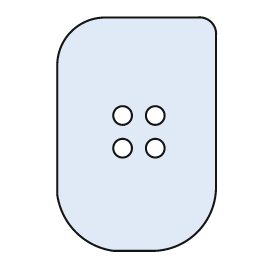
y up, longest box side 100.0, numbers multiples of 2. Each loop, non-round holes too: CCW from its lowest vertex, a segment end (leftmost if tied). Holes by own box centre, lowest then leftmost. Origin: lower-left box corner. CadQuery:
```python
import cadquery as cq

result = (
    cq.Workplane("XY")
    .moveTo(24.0, 0.0)
    .lineTo(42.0, 0.0)
    .threePointArc((60.0, 8.0), (68.0, 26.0))
    .lineTo(68.0, 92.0)
    .threePointArc((66.0, 98.0), (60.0, 100.0))
    .lineTo(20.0, 100.0)
    .threePointArc((6.0, 94.0), (0.0, 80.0))
    .lineTo(0.0, 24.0)
    .threePointArc((8.0, 8.0), (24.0, 0.0))
    .close()
    .moveTo(28.0, 44.0)
    .circle(4.0)
    .moveTo(42.0, 44.0)
    .circle(4.0)
    .moveTo(28.0, 58.0)
    .circle(4.0)
    .moveTo(42.0, 58.0)
    .circle(4.0)
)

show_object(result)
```